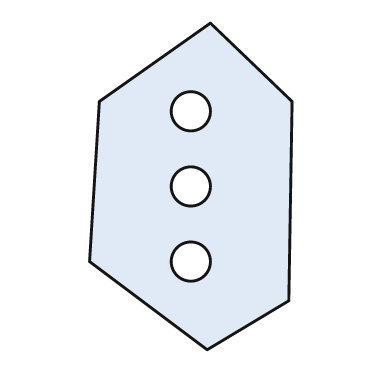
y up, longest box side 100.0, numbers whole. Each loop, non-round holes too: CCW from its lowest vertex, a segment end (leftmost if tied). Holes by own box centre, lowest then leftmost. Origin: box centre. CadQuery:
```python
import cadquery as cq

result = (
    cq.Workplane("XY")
    .moveTo(5.0, -50.0)
    .lineTo(30.0, -35.0)
    .lineTo(31.0, 26.0)
    .lineTo(6.0, 50.0)
    .lineTo(-28.0, 26.0)
    .lineTo(-31.0, -23.0)
    .close()
    .moveTo(0.0, -23.0)
    .circle(6.0)
    .moveTo(0.0, 0.0)
    .circle(6.0)
    .moveTo(0.0, 23.0)
    .circle(6.0)
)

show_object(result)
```